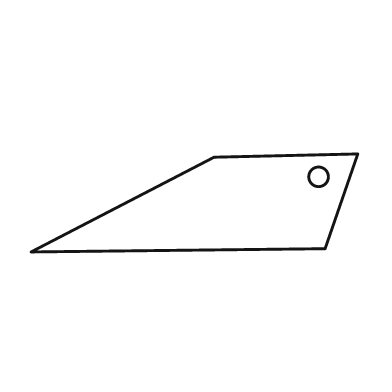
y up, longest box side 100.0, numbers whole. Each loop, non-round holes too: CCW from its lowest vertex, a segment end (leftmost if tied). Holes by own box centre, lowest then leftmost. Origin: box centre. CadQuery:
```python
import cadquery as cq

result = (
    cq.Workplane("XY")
    .moveTo(-50.0, -15.0)
    .lineTo(40.0, -14.0)
    .lineTo(50.0, 15.0)
    .lineTo(6.0, 14.0)
    .close()
    .moveTo(38.0, 8.0)
    .circle(3.0)
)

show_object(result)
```